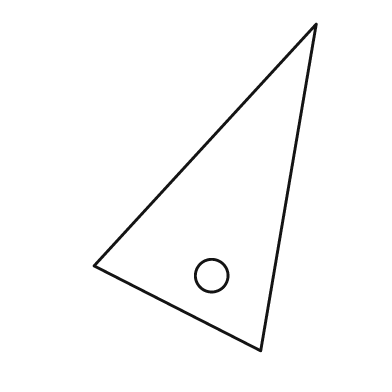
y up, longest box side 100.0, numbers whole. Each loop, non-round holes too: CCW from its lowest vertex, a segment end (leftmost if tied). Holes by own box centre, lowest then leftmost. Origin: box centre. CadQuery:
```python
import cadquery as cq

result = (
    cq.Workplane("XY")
    .moveTo(17.0, -50.0)
    .lineTo(34.0, 50.0)
    .lineTo(-34.0, -24.0)
    .close()
    .moveTo(2.0, -27.0)
    .circle(5.0)
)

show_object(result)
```